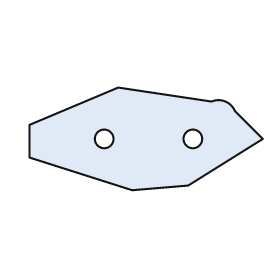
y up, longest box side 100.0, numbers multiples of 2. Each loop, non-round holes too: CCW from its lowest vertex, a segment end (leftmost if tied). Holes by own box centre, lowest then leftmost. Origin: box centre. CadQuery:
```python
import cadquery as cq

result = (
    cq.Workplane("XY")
    .moveTo(-6.0, -22.0)
    .lineTo(18.0, -20.0)
    .lineTo(50.0, 0.0)
    .lineTo(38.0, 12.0)
    .threePointArc((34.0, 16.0), (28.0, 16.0))
    .lineTo(-12.0, 22.0)
    .lineTo(-50.0, 6.0)
    .lineTo(-50.0, -8.0)
    .close()
    .moveTo(-18.0, 0.0)
    .circle(4.0)
    .moveTo(20.0, 0.0)
    .circle(4.0)
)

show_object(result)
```